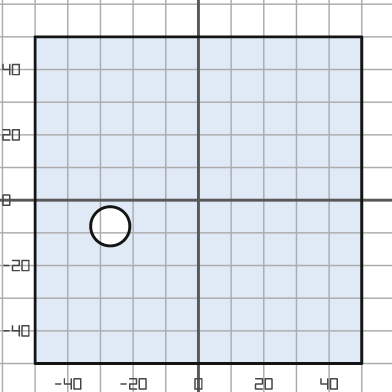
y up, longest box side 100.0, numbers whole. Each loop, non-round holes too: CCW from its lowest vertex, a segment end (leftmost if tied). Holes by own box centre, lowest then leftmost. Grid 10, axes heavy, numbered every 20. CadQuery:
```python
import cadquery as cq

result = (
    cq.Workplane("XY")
    .moveTo(-50.0, -50.0)
    .lineTo(50.0, -50.0)
    .lineTo(50.0, 50.0)
    .lineTo(-50.0, 50.0)
    .close()
    .moveTo(-27.0, -8.0)
    .circle(6.0)
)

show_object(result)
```